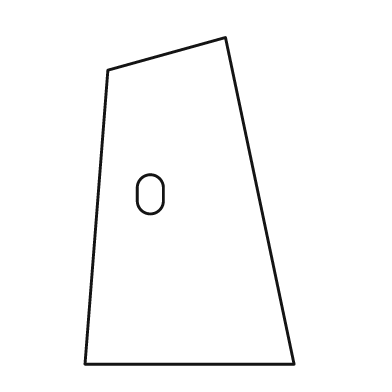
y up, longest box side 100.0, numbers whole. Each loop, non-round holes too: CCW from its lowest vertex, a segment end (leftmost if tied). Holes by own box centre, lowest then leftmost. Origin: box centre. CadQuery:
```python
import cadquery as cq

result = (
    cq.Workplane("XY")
    .moveTo(-32.0, -50.0)
    .lineTo(32.0, -50.0)
    .lineTo(11.0, 50.0)
    .lineTo(-25.0, 40.0)
    .close()
    .moveTo(-16.0, 0.0)
    .threePointArc((-12.0, -4.0), (-8.0, 0.0))
    .lineTo(-8.0, 4.0)
    .threePointArc((-12.0, 8.0), (-16.0, 4.0))
    .close()
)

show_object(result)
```